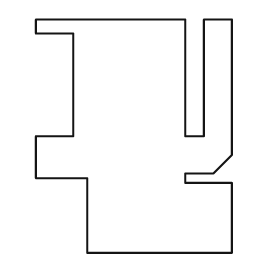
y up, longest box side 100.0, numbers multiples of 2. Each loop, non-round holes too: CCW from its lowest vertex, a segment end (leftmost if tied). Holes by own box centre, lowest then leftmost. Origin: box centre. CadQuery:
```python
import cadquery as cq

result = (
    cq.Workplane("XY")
    .moveTo(-20.0, -50.0)
    .lineTo(42.0, -50.0)
    .lineTo(42.0, -20.0)
    .lineTo(22.0, -20.0)
    .lineTo(22.0, -16.0)
    .lineTo(34.0, -16.0)
    .lineTo(42.0, -8.0)
    .lineTo(42.0, 50.0)
    .lineTo(30.0, 50.0)
    .lineTo(30.0, 0.0)
    .lineTo(22.0, 0.0)
    .lineTo(22.0, 50.0)
    .lineTo(-42.0, 50.0)
    .lineTo(-42.0, 44.0)
    .lineTo(-26.0, 44.0)
    .lineTo(-26.0, 0.0)
    .lineTo(-42.0, 0.0)
    .lineTo(-42.0, -18.0)
    .lineTo(-20.0, -18.0)
    .close()
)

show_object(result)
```